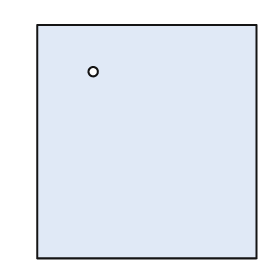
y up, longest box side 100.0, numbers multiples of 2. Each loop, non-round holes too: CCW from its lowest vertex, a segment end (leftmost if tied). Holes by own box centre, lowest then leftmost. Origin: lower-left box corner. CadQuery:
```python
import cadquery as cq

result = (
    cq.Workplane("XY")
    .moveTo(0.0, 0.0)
    .lineTo(94.0, 0.0)
    .lineTo(94.0, 100.0)
    .lineTo(0.0, 100.0)
    .close()
    .moveTo(24.0, 80.0)
    .circle(2.0)
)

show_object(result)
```